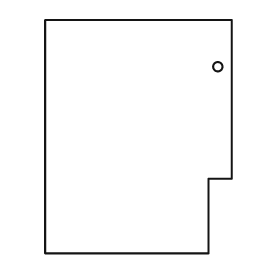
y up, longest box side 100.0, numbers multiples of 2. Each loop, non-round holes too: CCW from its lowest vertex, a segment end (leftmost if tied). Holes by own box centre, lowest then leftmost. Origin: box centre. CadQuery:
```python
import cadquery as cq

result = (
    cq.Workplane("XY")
    .moveTo(-40.0, -50.0)
    .lineTo(30.0, -50.0)
    .lineTo(30.0, -18.0)
    .lineTo(40.0, -18.0)
    .lineTo(40.0, 50.0)
    .lineTo(-40.0, 50.0)
    .close()
    .moveTo(34.0, 30.0)
    .circle(2.0)
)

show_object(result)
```